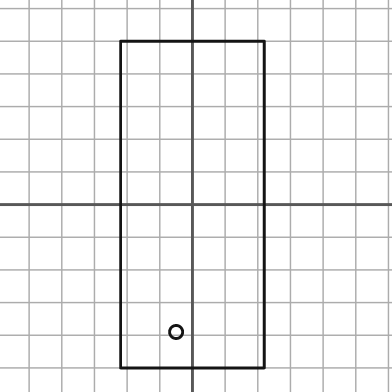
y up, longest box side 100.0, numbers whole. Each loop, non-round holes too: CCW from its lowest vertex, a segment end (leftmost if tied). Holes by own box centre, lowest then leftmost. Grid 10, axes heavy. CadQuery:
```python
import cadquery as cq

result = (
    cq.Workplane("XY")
    .moveTo(-22.0, -50.0)
    .lineTo(22.0, -50.0)
    .lineTo(22.0, 50.0)
    .lineTo(-22.0, 50.0)
    .close()
    .moveTo(-5.0, -39.0)
    .circle(2.0)
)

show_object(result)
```